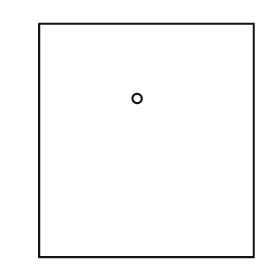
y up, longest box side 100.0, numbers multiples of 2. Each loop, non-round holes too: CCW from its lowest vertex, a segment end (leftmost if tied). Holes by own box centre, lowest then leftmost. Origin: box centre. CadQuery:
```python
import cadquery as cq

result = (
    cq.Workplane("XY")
    .moveTo(-46.0, -50.0)
    .lineTo(46.0, -50.0)
    .lineTo(46.0, 50.0)
    .lineTo(-46.0, 50.0)
    .close()
    .moveTo(-4.0, 18.0)
    .circle(2.0)
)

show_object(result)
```